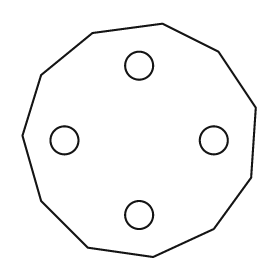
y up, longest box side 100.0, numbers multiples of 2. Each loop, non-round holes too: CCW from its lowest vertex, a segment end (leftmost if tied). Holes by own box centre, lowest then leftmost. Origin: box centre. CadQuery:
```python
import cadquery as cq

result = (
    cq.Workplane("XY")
    .moveTo(6.0, -50.0)
    .lineTo(32.0, -38.0)
    .lineTo(48.0, -16.0)
    .lineTo(50.0, 14.0)
    .lineTo(34.0, 38.0)
    .lineTo(10.0, 50.0)
    .lineTo(-20.0, 46.0)
    .lineTo(-42.0, 28.0)
    .lineTo(-50.0, 2.0)
    .lineTo(-42.0, -26.0)
    .lineTo(-22.0, -46.0)
    .close()
    .moveTo(0.0, -32.0)
    .circle(6.0)
    .moveTo(-32.0, 0.0)
    .circle(6.0)
    .moveTo(32.0, 0.0)
    .circle(6.0)
    .moveTo(0.0, 32.0)
    .circle(6.0)
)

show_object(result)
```